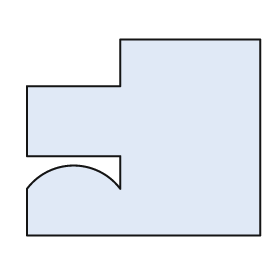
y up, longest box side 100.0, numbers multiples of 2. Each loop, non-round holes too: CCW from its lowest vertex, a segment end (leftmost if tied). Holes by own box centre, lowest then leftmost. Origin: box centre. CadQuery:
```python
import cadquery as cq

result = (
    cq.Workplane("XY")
    .moveTo(-50.0, -42.0)
    .lineTo(50.0, -42.0)
    .lineTo(50.0, 42.0)
    .lineTo(-10.0, 42.0)
    .lineTo(-10.0, 22.0)
    .lineTo(-50.0, 22.0)
    .lineTo(-50.0, -8.0)
    .lineTo(-10.0, -8.0)
    .lineTo(-10.0, -22.0)
    .threePointArc((-30.0, -12.0), (-50.0, -22.0))
    .close()
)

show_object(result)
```